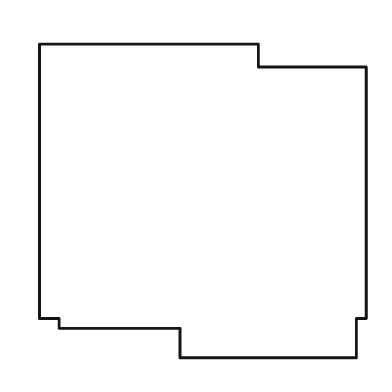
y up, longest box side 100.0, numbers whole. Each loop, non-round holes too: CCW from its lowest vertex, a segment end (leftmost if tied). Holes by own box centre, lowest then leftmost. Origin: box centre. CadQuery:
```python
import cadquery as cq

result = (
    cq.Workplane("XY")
    .moveTo(-7.0, -48.0)
    .lineTo(47.0, -48.0)
    .lineTo(47.0, -36.0)
    .lineTo(50.0, -36.0)
    .lineTo(50.0, 41.0)
    .lineTo(17.0, 41.0)
    .lineTo(17.0, 48.0)
    .lineTo(-50.0, 48.0)
    .lineTo(-50.0, -36.0)
    .lineTo(-44.0, -36.0)
    .lineTo(-44.0, -39.0)
    .lineTo(-7.0, -39.0)
    .close()
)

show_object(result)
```